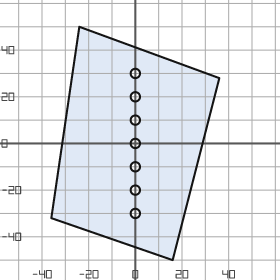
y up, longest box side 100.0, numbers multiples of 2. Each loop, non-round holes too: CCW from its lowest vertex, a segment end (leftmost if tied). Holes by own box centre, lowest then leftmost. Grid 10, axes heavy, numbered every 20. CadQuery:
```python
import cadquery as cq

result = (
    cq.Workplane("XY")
    .moveTo(16.0, -50.0)
    .lineTo(36.0, 28.0)
    .lineTo(-24.0, 50.0)
    .lineTo(-36.0, -32.0)
    .close()
    .moveTo(0.0, -30.0)
    .circle(2.0)
    .moveTo(0.0, -20.0)
    .circle(2.0)
    .moveTo(0.0, -10.0)
    .circle(2.0)
    .moveTo(0.0, 0.0)
    .circle(2.0)
    .moveTo(0.0, 10.0)
    .circle(2.0)
    .moveTo(0.0, 20.0)
    .circle(2.0)
    .moveTo(0.0, 30.0)
    .circle(2.0)
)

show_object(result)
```